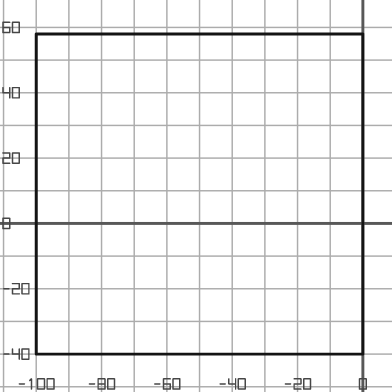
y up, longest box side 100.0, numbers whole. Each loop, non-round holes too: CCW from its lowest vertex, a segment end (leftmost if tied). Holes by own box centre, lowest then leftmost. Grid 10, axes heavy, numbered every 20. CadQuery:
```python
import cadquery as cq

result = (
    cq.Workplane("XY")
    .moveTo(-100.0, -40.0)
    .lineTo(0.0, -40.0)
    .lineTo(0.0, 58.0)
    .lineTo(-100.0, 58.0)
    .close()
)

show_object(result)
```